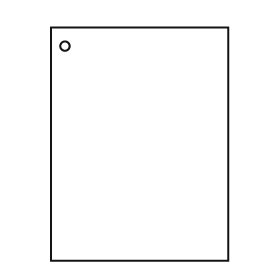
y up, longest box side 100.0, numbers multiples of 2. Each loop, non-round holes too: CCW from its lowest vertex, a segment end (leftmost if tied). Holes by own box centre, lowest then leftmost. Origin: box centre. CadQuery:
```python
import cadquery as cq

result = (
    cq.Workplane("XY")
    .moveTo(-38.0, -50.0)
    .lineTo(38.0, -50.0)
    .lineTo(38.0, 50.0)
    .lineTo(-38.0, 50.0)
    .close()
    .moveTo(-32.0, 42.0)
    .circle(2.0)
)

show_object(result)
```